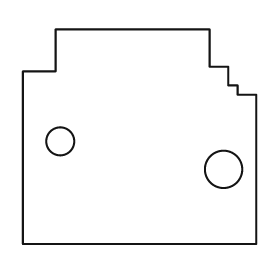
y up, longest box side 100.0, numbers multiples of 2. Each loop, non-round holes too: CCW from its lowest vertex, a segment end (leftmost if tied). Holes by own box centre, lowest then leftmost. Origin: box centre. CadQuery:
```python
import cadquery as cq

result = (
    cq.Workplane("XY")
    .moveTo(-50.0, -46.0)
    .lineTo(50.0, -46.0)
    .lineTo(50.0, 18.0)
    .lineTo(42.0, 18.0)
    .lineTo(42.0, 22.0)
    .lineTo(38.0, 22.0)
    .lineTo(38.0, 30.0)
    .lineTo(30.0, 30.0)
    .lineTo(30.0, 46.0)
    .lineTo(-36.0, 46.0)
    .lineTo(-36.0, 28.0)
    .lineTo(-50.0, 28.0)
    .close()
    .moveTo(36.0, -14.0)
    .circle(8.0)
    .moveTo(-34.0, -2.0)
    .circle(6.0)
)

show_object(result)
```